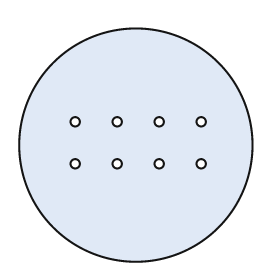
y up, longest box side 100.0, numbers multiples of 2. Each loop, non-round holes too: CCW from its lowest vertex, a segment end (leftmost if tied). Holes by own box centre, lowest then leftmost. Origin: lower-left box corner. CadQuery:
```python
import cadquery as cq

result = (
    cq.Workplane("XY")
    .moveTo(50.0, 50.0)
    .circle(50.0)
    .moveTo(24.0, 42.0)
    .circle(2.0)
    .moveTo(42.0, 42.0)
    .circle(2.0)
    .moveTo(60.0, 42.0)
    .circle(2.0)
    .moveTo(78.0, 42.0)
    .circle(2.0)
    .moveTo(24.0, 60.0)
    .circle(2.0)
    .moveTo(42.0, 60.0)
    .circle(2.0)
    .moveTo(60.0, 60.0)
    .circle(2.0)
    .moveTo(78.0, 60.0)
    .circle(2.0)
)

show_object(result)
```